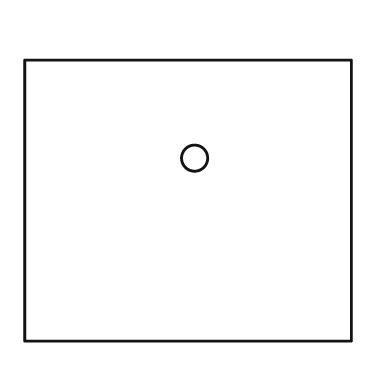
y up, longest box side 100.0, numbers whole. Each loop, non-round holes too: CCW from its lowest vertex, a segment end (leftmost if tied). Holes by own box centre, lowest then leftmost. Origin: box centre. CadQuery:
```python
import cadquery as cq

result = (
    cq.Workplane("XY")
    .moveTo(-50.0, -43.0)
    .lineTo(50.0, -43.0)
    .lineTo(50.0, 43.0)
    .lineTo(-50.0, 43.0)
    .close()
    .moveTo(2.0, 13.0)
    .circle(4.0)
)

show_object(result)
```